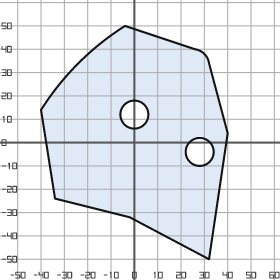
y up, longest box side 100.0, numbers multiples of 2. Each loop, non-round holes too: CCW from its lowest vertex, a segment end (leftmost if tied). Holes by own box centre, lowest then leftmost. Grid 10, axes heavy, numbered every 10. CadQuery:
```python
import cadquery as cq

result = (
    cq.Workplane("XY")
    .moveTo(32.0, -50.0)
    .lineTo(40.0, 4.0)
    .lineTo(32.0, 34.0)
    .threePointArc((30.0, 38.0), (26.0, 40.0))
    .lineTo(-4.0, 50.0)
    .threePointArc((-24.0, 34.0), (-40.0, 14.0))
    .lineTo(-34.0, -24.0)
    .lineTo(-2.0, -32.0)
    .close()
    .moveTo(28.0, -4.0)
    .circle(6.0)
    .moveTo(0.0, 12.0)
    .circle(6.0)
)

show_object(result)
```